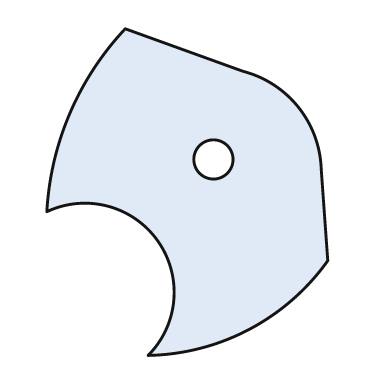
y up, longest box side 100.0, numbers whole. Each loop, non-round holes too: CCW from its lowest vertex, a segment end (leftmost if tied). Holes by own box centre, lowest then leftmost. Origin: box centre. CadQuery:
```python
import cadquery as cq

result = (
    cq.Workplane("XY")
    .moveTo(-12.0, -50.0)
    .threePointArc((19.0, -42.0), (43.0, -21.0))
    .lineTo(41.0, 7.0)
    .threePointArc((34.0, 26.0), (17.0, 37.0))
    .lineTo(-19.0, 50.0)
    .threePointArc((-36.0, 24.0), (-43.0, -6.0))
    .threePointArc((-9.0, -15.0), (-12.0, -50.0))
    .close()
    .moveTo(8.0, 10.0)
    .circle(6.0)
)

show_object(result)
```